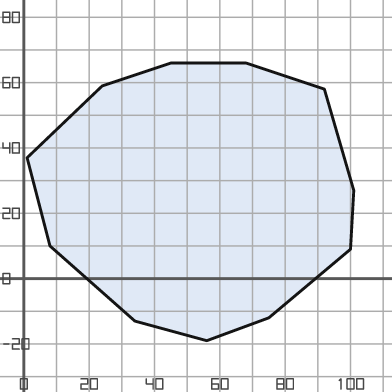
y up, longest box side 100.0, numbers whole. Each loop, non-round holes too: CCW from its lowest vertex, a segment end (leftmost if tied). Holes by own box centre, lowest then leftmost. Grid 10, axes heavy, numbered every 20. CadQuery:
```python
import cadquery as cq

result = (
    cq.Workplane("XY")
    .moveTo(56.0, -19.0)
    .lineTo(75.0, -12.0)
    .lineTo(100.0, 9.0)
    .lineTo(101.0, 27.0)
    .lineTo(92.0, 58.0)
    .lineTo(68.0, 66.0)
    .lineTo(45.0, 66.0)
    .lineTo(24.0, 59.0)
    .lineTo(1.0, 37.0)
    .lineTo(8.0, 10.0)
    .lineTo(34.0, -13.0)
    .close()
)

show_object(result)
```